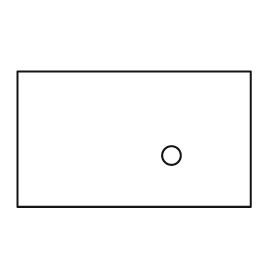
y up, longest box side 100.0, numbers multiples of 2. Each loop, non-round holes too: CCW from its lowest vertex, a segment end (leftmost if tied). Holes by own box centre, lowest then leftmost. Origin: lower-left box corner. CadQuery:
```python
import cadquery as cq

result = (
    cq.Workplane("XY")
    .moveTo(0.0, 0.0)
    .lineTo(100.0, 0.0)
    .lineTo(100.0, 58.0)
    .lineTo(0.0, 58.0)
    .close()
    .moveTo(66.0, 22.0)
    .circle(4.0)
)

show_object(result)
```